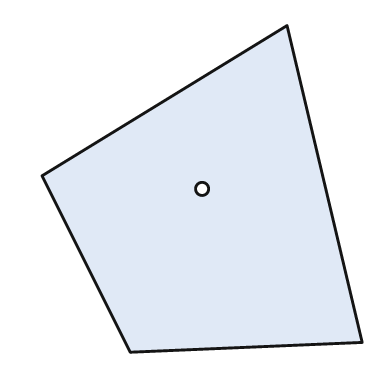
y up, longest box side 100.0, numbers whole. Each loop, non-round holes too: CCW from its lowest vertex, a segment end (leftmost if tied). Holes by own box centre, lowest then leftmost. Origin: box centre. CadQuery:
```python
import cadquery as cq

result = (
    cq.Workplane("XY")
    .moveTo(-22.0, -50.0)
    .lineTo(49.0, -47.0)
    .lineTo(26.0, 50.0)
    .lineTo(-49.0, 4.0)
    .close()
    .moveTo(0.0, 0.0)
    .circle(2.0)
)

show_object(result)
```